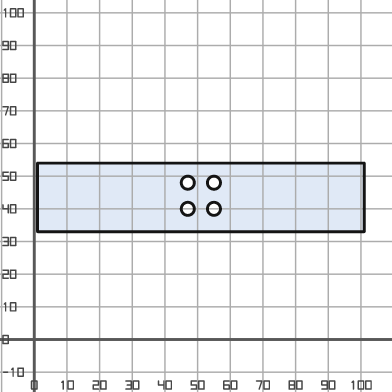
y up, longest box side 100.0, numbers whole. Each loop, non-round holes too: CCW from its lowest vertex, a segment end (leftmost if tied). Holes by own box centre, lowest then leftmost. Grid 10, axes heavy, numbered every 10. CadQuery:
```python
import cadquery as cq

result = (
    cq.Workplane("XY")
    .moveTo(1.0, 33.0)
    .lineTo(101.0, 33.0)
    .lineTo(101.0, 54.0)
    .lineTo(1.0, 54.0)
    .close()
    .moveTo(47.0, 40.0)
    .circle(2.0)
    .moveTo(55.0, 40.0)
    .circle(2.0)
    .moveTo(47.0, 48.0)
    .circle(2.0)
    .moveTo(55.0, 48.0)
    .circle(2.0)
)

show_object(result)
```